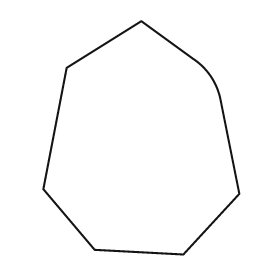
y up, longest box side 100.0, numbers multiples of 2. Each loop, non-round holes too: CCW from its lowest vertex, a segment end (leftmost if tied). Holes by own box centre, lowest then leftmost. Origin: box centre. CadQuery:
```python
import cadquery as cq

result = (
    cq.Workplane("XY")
    .moveTo(18.0, -50.0)
    .lineTo(42.0, -24.0)
    .lineTo(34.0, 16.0)
    .threePointArc((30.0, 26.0), (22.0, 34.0))
    .lineTo(0.0, 50.0)
    .lineTo(-32.0, 30.0)
    .lineTo(-42.0, -22.0)
    .lineTo(-20.0, -48.0)
    .close()
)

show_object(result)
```